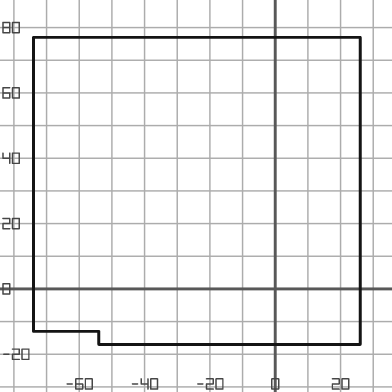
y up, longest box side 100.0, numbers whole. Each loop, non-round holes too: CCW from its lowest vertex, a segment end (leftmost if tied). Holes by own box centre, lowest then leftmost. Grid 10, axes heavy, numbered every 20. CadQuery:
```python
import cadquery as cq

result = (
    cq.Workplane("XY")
    .moveTo(-54.0, -17.0)
    .lineTo(26.0, -17.0)
    .lineTo(26.0, 77.0)
    .lineTo(-74.0, 77.0)
    .lineTo(-74.0, -13.0)
    .lineTo(-54.0, -13.0)
    .close()
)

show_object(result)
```